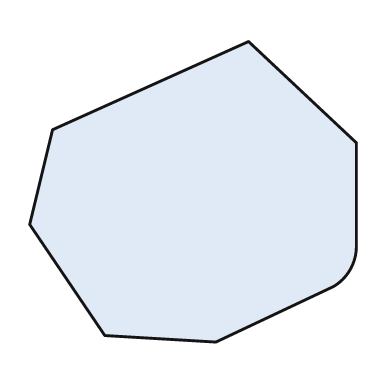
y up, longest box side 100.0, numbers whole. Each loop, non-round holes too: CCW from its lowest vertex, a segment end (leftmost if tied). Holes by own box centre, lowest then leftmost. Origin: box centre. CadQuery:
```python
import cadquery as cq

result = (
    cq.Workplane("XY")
    .moveTo(7.0, -46.0)
    .lineTo(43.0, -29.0)
    .threePointArc((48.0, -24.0), (50.0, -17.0))
    .lineTo(50.0, 15.0)
    .lineTo(17.0, 46.0)
    .lineTo(-43.0, 19.0)
    .lineTo(-50.0, -10.0)
    .lineTo(-27.0, -44.0)
    .close()
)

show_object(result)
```